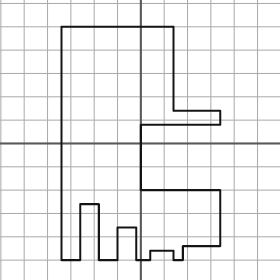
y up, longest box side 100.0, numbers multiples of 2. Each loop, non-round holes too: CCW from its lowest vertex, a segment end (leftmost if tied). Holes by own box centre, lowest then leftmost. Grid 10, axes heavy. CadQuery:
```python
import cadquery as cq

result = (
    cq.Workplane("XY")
    .moveTo(-34.0, -50.0)
    .lineTo(-26.0, -50.0)
    .lineTo(-26.0, -26.0)
    .lineTo(-18.0, -26.0)
    .lineTo(-18.0, -50.0)
    .lineTo(-10.0, -50.0)
    .lineTo(-10.0, -36.0)
    .lineTo(-2.0, -36.0)
    .lineTo(-2.0, -50.0)
    .lineTo(4.0, -50.0)
    .lineTo(4.0, -46.0)
    .lineTo(14.0, -46.0)
    .lineTo(14.0, -50.0)
    .lineTo(18.0, -50.0)
    .lineTo(18.0, -44.0)
    .lineTo(34.0, -44.0)
    .lineTo(34.0, -20.0)
    .lineTo(0.0, -20.0)
    .lineTo(0.0, 8.0)
    .lineTo(34.0, 8.0)
    .lineTo(34.0, 14.0)
    .lineTo(14.0, 14.0)
    .lineTo(14.0, 50.0)
    .lineTo(-34.0, 50.0)
    .close()
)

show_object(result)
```